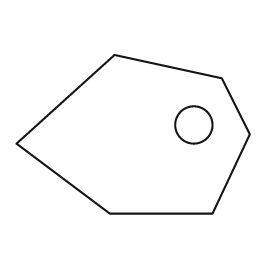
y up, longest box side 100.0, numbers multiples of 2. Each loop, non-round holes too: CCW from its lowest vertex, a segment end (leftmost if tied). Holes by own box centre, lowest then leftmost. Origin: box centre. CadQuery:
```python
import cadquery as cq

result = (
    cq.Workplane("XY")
    .moveTo(-10.0, -34.0)
    .lineTo(34.0, -34.0)
    .lineTo(50.0, 0.0)
    .lineTo(38.0, 24.0)
    .lineTo(-8.0, 34.0)
    .lineTo(-50.0, -4.0)
    .close()
    .moveTo(26.0, 4.0)
    .circle(8.0)
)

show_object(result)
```